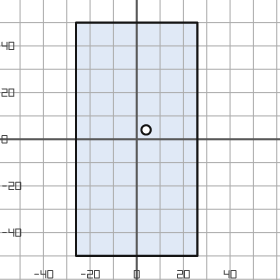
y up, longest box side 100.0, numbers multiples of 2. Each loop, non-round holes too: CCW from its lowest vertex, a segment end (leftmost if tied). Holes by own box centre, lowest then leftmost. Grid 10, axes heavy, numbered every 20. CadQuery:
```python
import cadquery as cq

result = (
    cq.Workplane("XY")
    .moveTo(-26.0, -50.0)
    .lineTo(26.0, -50.0)
    .lineTo(26.0, 50.0)
    .lineTo(-26.0, 50.0)
    .close()
    .moveTo(4.0, 4.0)
    .circle(2.0)
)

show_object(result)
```